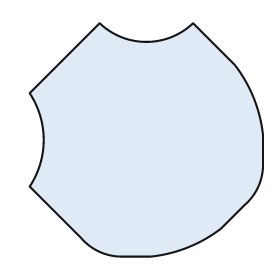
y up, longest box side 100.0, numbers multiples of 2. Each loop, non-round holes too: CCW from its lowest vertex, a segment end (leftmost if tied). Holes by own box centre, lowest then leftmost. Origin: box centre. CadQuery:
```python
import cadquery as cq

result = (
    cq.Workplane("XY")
    .moveTo(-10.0, -50.0)
    .lineTo(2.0, -50.0)
    .threePointArc((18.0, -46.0), (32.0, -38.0))
    .lineTo(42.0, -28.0)
    .threePointArc((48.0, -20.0), (50.0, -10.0))
    .lineTo(50.0, 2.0)
    .threePointArc((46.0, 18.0), (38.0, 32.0))
    .lineTo(20.0, 50.0)
    .threePointArc((0.0, 42.0), (-20.0, 50.0))
    .lineTo(-50.0, 20.0)
    .threePointArc((-44.0, 0.0), (-50.0, -20.0))
    .lineTo(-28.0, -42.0)
    .threePointArc((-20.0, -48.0), (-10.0, -50.0))
    .close()
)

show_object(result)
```